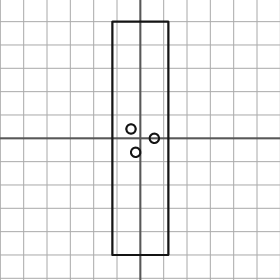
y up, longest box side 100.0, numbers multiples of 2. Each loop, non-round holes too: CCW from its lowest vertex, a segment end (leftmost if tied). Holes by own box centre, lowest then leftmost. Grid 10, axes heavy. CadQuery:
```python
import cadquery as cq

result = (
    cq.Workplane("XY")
    .moveTo(-12.0, -50.0)
    .lineTo(12.0, -50.0)
    .lineTo(12.0, 50.0)
    .lineTo(-12.0, 50.0)
    .close()
    .moveTo(-2.0, -6.0)
    .circle(2.0)
    .moveTo(6.0, 0.0)
    .circle(2.0)
    .moveTo(-4.0, 4.0)
    .circle(2.0)
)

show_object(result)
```